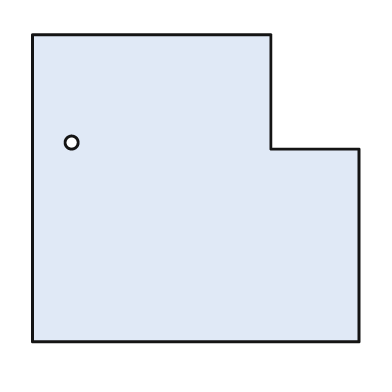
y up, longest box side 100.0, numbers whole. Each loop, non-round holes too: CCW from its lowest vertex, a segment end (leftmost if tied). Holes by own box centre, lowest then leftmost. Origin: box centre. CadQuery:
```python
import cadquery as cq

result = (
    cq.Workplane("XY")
    .moveTo(-50.0, -47.0)
    .lineTo(50.0, -47.0)
    .lineTo(50.0, 12.0)
    .lineTo(23.0, 12.0)
    .lineTo(23.0, 47.0)
    .lineTo(-50.0, 47.0)
    .close()
    .moveTo(-38.0, 14.0)
    .circle(2.0)
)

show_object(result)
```